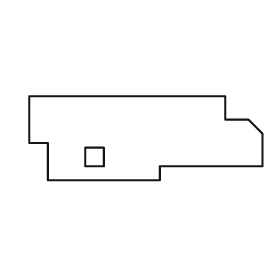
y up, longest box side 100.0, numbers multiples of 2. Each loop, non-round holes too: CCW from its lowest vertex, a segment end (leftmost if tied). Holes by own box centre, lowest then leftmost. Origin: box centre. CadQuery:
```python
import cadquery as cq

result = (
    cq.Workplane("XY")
    .moveTo(-42.0, -18.0)
    .lineTo(6.0, -18.0)
    .lineTo(6.0, -12.0)
    .lineTo(50.0, -12.0)
    .lineTo(50.0, 2.0)
    .lineTo(44.0, 8.0)
    .lineTo(34.0, 8.0)
    .lineTo(34.0, 18.0)
    .lineTo(-50.0, 18.0)
    .lineTo(-50.0, -2.0)
    .lineTo(-42.0, -2.0)
    .close()
    .moveTo(-26.0, -12.0)
    .lineTo(-18.0, -12.0)
    .lineTo(-18.0, -4.0)
    .lineTo(-26.0, -4.0)
    .close()
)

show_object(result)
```